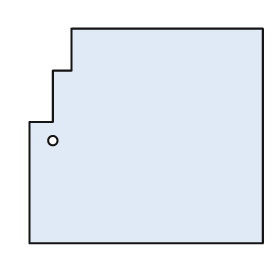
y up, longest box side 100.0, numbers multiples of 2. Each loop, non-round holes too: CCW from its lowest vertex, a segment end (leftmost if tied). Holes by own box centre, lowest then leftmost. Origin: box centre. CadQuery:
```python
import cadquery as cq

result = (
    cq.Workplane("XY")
    .moveTo(-50.0, -46.0)
    .lineTo(50.0, -46.0)
    .lineTo(50.0, 46.0)
    .lineTo(-32.0, 46.0)
    .lineTo(-32.0, 28.0)
    .lineTo(-40.0, 28.0)
    .lineTo(-40.0, 6.0)
    .lineTo(-50.0, 6.0)
    .close()
    .moveTo(-40.0, -2.0)
    .circle(2.0)
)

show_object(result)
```